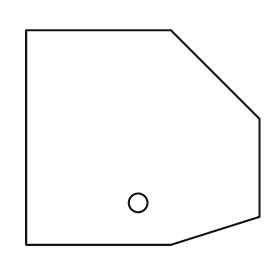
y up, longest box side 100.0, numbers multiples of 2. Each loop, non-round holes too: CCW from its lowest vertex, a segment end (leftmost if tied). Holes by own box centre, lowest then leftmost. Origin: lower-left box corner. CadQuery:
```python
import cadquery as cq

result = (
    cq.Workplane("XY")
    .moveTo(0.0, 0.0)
    .lineTo(62.0, 0.0)
    .lineTo(100.0, 12.0)
    .lineTo(100.0, 54.0)
    .lineTo(62.0, 92.0)
    .lineTo(0.0, 92.0)
    .close()
    .moveTo(48.0, 18.0)
    .circle(4.0)
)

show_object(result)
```